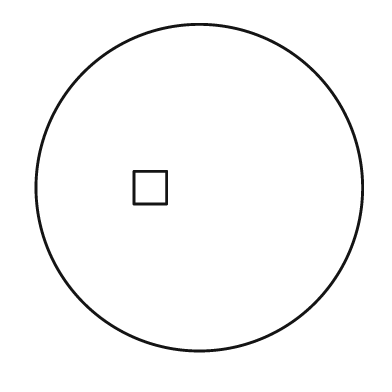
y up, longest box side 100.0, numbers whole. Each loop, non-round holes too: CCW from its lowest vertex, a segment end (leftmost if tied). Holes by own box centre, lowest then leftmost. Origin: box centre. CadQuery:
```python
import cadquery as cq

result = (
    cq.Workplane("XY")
    .moveTo(0.0, 0.0)
    .circle(50.0)
    .moveTo(-20.0, -5.0)
    .lineTo(-10.0, -5.0)
    .lineTo(-10.0, 5.0)
    .lineTo(-20.0, 5.0)
    .close()
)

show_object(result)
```